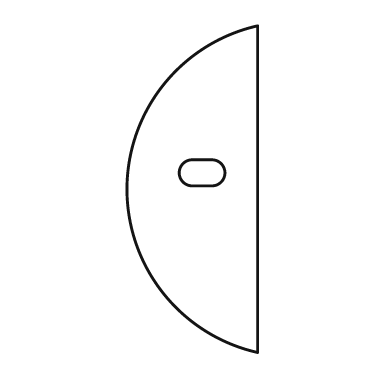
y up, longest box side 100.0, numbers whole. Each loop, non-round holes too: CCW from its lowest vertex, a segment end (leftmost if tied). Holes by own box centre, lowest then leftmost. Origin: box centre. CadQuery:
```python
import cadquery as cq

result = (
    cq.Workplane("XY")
    .moveTo(20.0, -50.0)
    .lineTo(20.0, 50.0)
    .threePointArc((-20.0, 0.0), (20.0, -50.0))
    .close()
    .moveTo(0.0, 1.0)
    .lineTo(6.0, 1.0)
    .threePointArc((10.0, 5.0), (6.0, 9.0))
    .lineTo(0.0, 9.0)
    .threePointArc((-4.0, 5.0), (0.0, 1.0))
    .close()
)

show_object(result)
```